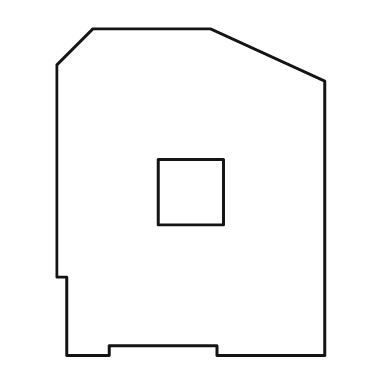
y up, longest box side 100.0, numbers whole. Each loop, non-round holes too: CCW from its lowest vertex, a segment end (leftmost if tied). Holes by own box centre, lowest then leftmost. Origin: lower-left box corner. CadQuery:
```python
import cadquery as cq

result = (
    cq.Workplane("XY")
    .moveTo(3.0, 0.0)
    .lineTo(16.0, 0.0)
    .lineTo(16.0, 3.0)
    .lineTo(49.0, 3.0)
    .lineTo(49.0, 0.0)
    .lineTo(82.0, 0.0)
    .lineTo(82.0, 84.0)
    .lineTo(47.0, 100.0)
    .lineTo(11.0, 100.0)
    .lineTo(0.0, 89.0)
    .lineTo(0.0, 24.0)
    .lineTo(3.0, 24.0)
    .close()
    .moveTo(31.0, 40.0)
    .lineTo(51.0, 40.0)
    .lineTo(51.0, 60.0)
    .lineTo(31.0, 60.0)
    .close()
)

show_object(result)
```